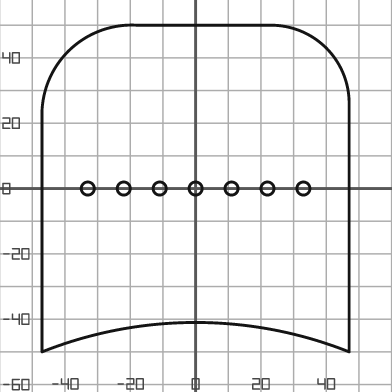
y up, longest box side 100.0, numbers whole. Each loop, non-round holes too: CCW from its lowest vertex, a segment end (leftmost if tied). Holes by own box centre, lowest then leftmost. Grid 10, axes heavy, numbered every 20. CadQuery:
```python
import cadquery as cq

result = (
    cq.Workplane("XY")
    .moveTo(-47.0, -50.0)
    .threePointArc((0.0, -41.0), (47.0, -50.0))
    .lineTo(47.0, 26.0)
    .threePointArc((40.0, 43.0), (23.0, 50.0))
    .lineTo(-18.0, 50.0)
    .threePointArc((-39.0, 42.0), (-47.0, 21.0))
    .close()
    .moveTo(-33.0, 0.0)
    .circle(2.0)
    .moveTo(-22.0, 0.0)
    .circle(2.0)
    .moveTo(-11.0, 0.0)
    .circle(2.0)
    .moveTo(0.0, 0.0)
    .circle(2.0)
    .moveTo(11.0, 0.0)
    .circle(2.0)
    .moveTo(22.0, 0.0)
    .circle(2.0)
    .moveTo(33.0, 0.0)
    .circle(2.0)
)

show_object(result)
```